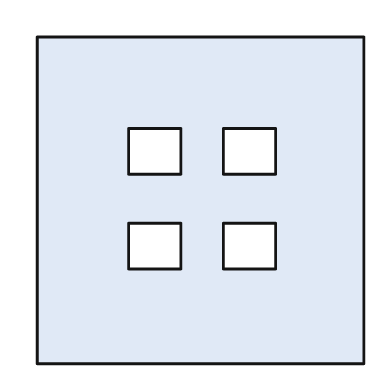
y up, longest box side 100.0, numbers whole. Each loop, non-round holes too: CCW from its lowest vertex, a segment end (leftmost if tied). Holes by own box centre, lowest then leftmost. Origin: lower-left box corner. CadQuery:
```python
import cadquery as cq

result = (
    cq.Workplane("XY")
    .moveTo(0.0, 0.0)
    .lineTo(100.0, 0.0)
    .lineTo(100.0, 100.0)
    .lineTo(0.0, 100.0)
    .close()
    .moveTo(28.0, 29.0)
    .lineTo(44.0, 29.0)
    .lineTo(44.0, 43.0)
    .lineTo(28.0, 43.0)
    .close()
    .moveTo(57.0, 29.0)
    .lineTo(73.0, 29.0)
    .lineTo(73.0, 43.0)
    .lineTo(57.0, 43.0)
    .close()
    .moveTo(28.0, 58.0)
    .lineTo(44.0, 58.0)
    .lineTo(44.0, 72.0)
    .lineTo(28.0, 72.0)
    .close()
    .moveTo(57.0, 58.0)
    .lineTo(73.0, 58.0)
    .lineTo(73.0, 72.0)
    .lineTo(57.0, 72.0)
    .close()
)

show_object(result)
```